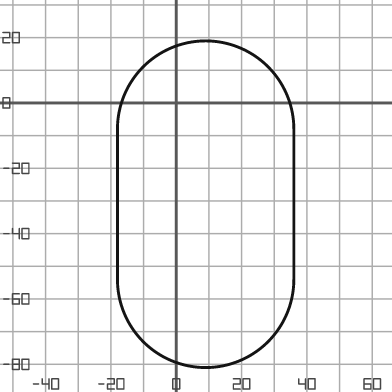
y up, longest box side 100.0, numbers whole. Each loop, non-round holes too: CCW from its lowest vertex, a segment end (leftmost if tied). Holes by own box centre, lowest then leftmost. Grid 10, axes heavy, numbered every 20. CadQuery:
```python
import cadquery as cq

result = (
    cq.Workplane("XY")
    .moveTo(-18.0, -54.0)
    .threePointArc((9.0, -81.0), (36.0, -54.0))
    .lineTo(36.0, -8.0)
    .threePointArc((9.0, 19.0), (-18.0, -8.0))
    .close()
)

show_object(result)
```